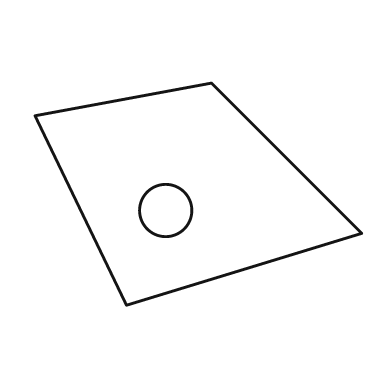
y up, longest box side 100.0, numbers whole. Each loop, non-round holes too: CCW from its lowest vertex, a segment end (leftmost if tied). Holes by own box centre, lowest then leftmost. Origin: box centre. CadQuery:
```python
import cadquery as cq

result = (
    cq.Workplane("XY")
    .moveTo(-22.0, -34.0)
    .lineTo(50.0, -12.0)
    .lineTo(4.0, 34.0)
    .lineTo(-50.0, 24.0)
    .close()
    .moveTo(-10.0, -5.0)
    .circle(8.0)
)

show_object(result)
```